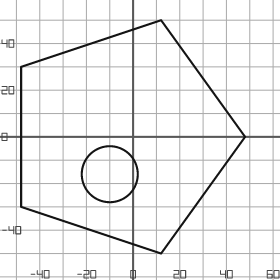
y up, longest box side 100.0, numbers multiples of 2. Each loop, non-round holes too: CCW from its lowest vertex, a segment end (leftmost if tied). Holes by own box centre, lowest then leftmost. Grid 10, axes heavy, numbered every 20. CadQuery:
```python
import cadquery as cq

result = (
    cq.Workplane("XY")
    .moveTo(12.0, -50.0)
    .lineTo(48.0, 0.0)
    .lineTo(12.0, 50.0)
    .lineTo(-48.0, 30.0)
    .lineTo(-48.0, -30.0)
    .close()
    .moveTo(-10.0, -16.0)
    .circle(12.0)
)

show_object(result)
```